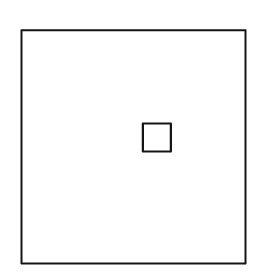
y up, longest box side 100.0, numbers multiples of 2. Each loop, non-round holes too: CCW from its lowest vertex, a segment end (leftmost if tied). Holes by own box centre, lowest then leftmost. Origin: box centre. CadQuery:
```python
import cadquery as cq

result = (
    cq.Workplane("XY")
    .moveTo(-48.0, -50.0)
    .lineTo(48.0, -50.0)
    .lineTo(48.0, 50.0)
    .lineTo(-48.0, 50.0)
    .close()
    .moveTo(4.0, -2.0)
    .lineTo(16.0, -2.0)
    .lineTo(16.0, 10.0)
    .lineTo(4.0, 10.0)
    .close()
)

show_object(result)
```